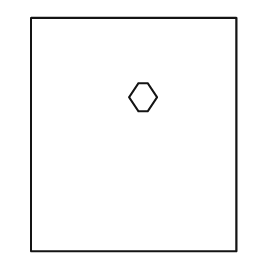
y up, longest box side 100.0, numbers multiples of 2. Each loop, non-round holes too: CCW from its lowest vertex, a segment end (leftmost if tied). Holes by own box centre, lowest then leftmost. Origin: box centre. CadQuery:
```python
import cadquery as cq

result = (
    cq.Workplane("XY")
    .moveTo(-44.0, -50.0)
    .lineTo(44.0, -50.0)
    .lineTo(44.0, 50.0)
    .lineTo(-44.0, 50.0)
    .close()
    .moveTo(2.0, 10.0)
    .lineTo(6.0, 10.0)
    .lineTo(10.0, 16.0)
    .lineTo(6.0, 22.0)
    .lineTo(2.0, 22.0)
    .lineTo(-2.0, 16.0)
    .close()
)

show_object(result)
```